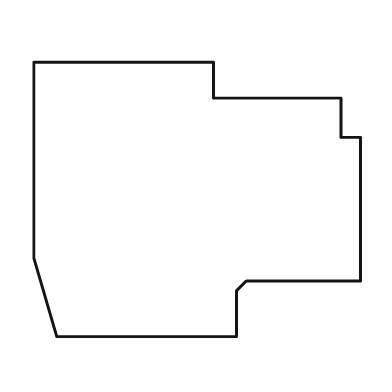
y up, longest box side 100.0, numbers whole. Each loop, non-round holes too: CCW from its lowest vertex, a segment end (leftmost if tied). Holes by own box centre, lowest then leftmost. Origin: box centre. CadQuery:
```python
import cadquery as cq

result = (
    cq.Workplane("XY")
    .moveTo(-43.0, -42.0)
    .lineTo(12.0, -42.0)
    .lineTo(12.0, -28.0)
    .lineTo(15.0, -25.0)
    .lineTo(50.0, -25.0)
    .lineTo(50.0, 19.0)
    .lineTo(44.0, 19.0)
    .lineTo(44.0, 31.0)
    .lineTo(5.0, 31.0)
    .lineTo(5.0, 42.0)
    .lineTo(-50.0, 42.0)
    .lineTo(-50.0, -18.0)
    .close()
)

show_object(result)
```